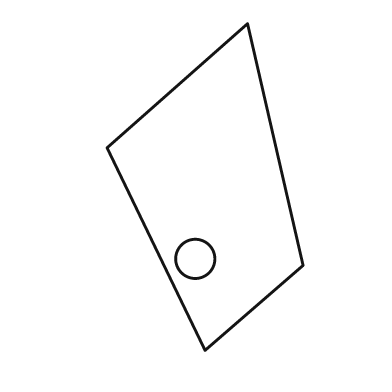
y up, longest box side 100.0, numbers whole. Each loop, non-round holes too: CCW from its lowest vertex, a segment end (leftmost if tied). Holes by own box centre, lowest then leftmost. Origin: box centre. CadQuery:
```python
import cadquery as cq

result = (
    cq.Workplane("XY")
    .moveTo(0.0, -50.0)
    .lineTo(30.0, -24.0)
    .lineTo(13.0, 50.0)
    .lineTo(-30.0, 12.0)
    .close()
    .moveTo(-3.0, -22.0)
    .circle(6.0)
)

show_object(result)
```